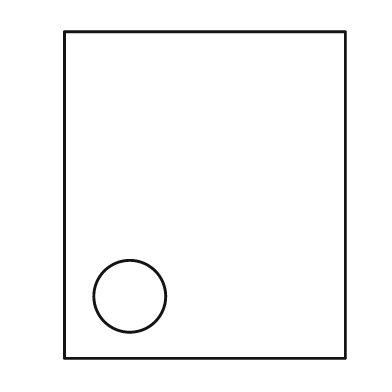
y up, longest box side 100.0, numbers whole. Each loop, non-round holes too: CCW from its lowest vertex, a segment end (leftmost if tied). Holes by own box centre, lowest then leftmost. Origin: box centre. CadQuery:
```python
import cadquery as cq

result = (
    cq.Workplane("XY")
    .moveTo(-43.0, -50.0)
    .lineTo(43.0, -50.0)
    .lineTo(43.0, 50.0)
    .lineTo(-43.0, 50.0)
    .close()
    .moveTo(-23.0, -31.0)
    .circle(11.0)
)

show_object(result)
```